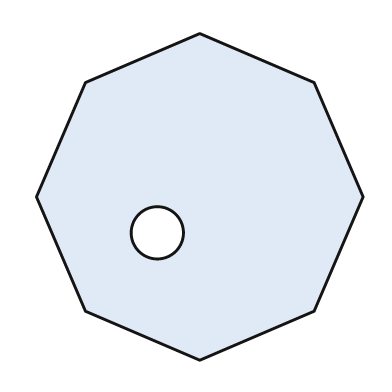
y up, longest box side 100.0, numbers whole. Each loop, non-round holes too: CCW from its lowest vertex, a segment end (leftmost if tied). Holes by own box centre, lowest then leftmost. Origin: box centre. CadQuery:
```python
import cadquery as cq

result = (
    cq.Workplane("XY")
    .moveTo(0.0, -50.0)
    .lineTo(35.0, -35.0)
    .lineTo(50.0, 0.0)
    .lineTo(35.0, 35.0)
    .lineTo(0.0, 50.0)
    .lineTo(-35.0, 35.0)
    .lineTo(-50.0, 0.0)
    .lineTo(-35.0, -35.0)
    .close()
    .moveTo(-13.0, -11.0)
    .circle(8.0)
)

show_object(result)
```